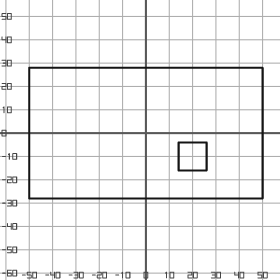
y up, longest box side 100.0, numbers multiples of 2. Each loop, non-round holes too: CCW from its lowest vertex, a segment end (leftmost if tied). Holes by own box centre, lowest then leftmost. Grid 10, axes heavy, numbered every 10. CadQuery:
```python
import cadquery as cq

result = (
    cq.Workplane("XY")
    .moveTo(-50.0, -28.0)
    .lineTo(50.0, -28.0)
    .lineTo(50.0, 28.0)
    .lineTo(-50.0, 28.0)
    .close()
    .moveTo(14.0, -16.0)
    .lineTo(26.0, -16.0)
    .lineTo(26.0, -4.0)
    .lineTo(14.0, -4.0)
    .close()
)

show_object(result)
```